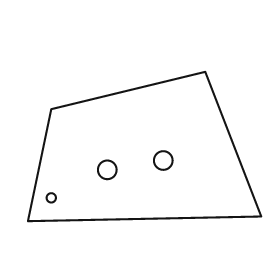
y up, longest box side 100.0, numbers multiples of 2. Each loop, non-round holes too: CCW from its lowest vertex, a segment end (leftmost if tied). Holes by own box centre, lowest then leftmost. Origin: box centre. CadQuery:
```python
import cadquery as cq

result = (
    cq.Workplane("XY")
    .moveTo(-50.0, -32.0)
    .lineTo(50.0, -30.0)
    .lineTo(26.0, 32.0)
    .lineTo(-40.0, 16.0)
    .close()
    .moveTo(-40.0, -22.0)
    .circle(2.0)
    .moveTo(-16.0, -10.0)
    .circle(4.0)
    .moveTo(8.0, -6.0)
    .circle(4.0)
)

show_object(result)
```